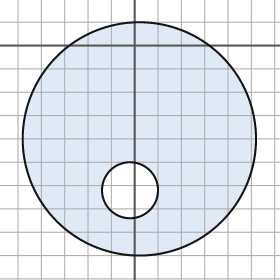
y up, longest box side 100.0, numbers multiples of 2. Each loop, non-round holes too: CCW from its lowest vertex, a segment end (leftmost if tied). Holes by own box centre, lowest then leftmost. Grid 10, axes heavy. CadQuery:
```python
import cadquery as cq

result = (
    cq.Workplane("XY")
    .moveTo(2.0, -40.0)
    .circle(50.0)
    .moveTo(-2.0, -62.0)
    .circle(12.0)
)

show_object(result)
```